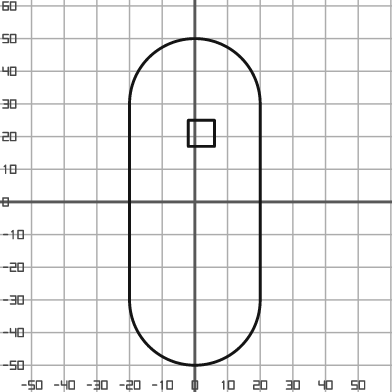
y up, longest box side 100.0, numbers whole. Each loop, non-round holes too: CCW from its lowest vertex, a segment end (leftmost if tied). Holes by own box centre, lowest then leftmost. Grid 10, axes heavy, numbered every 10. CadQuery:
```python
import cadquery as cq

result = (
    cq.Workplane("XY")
    .moveTo(-20.0, -30.0)
    .threePointArc((0.0, -50.0), (20.0, -30.0))
    .lineTo(20.0, 30.0)
    .threePointArc((0.0, 50.0), (-20.0, 30.0))
    .close()
    .moveTo(-2.0, 17.0)
    .lineTo(6.0, 17.0)
    .lineTo(6.0, 25.0)
    .lineTo(-2.0, 25.0)
    .close()
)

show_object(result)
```